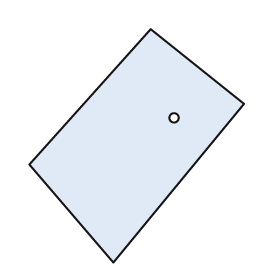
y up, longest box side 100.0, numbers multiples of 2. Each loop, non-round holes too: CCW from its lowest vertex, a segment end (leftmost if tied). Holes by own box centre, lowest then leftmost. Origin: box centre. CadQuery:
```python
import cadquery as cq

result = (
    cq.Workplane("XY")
    .moveTo(-10.0, -50.0)
    .lineTo(46.0, 18.0)
    .lineTo(6.0, 50.0)
    .lineTo(-46.0, -8.0)
    .close()
    .moveTo(16.0, 12.0)
    .circle(2.0)
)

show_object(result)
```